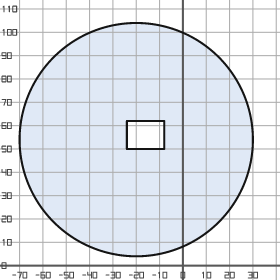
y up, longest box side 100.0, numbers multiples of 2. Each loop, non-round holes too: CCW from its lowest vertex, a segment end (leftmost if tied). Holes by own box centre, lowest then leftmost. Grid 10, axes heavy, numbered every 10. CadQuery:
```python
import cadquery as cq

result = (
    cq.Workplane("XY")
    .moveTo(-20.0, 54.0)
    .circle(50.0)
    .moveTo(-24.0, 50.0)
    .lineTo(-8.0, 50.0)
    .lineTo(-8.0, 62.0)
    .lineTo(-24.0, 62.0)
    .close()
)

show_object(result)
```